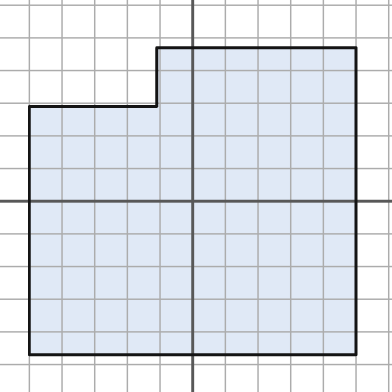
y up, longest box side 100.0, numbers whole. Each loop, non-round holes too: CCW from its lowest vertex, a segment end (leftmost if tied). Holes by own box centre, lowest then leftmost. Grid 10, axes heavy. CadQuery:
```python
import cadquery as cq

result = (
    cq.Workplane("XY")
    .moveTo(-50.0, -47.0)
    .lineTo(50.0, -47.0)
    .lineTo(50.0, 47.0)
    .lineTo(-11.0, 47.0)
    .lineTo(-11.0, 29.0)
    .lineTo(-50.0, 29.0)
    .close()
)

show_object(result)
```